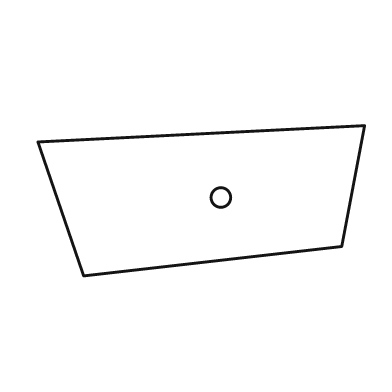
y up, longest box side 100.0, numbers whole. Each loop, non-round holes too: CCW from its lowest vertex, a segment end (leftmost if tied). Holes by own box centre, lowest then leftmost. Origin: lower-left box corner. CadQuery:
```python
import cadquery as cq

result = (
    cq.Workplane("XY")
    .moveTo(14.0, 0.0)
    .lineTo(93.0, 9.0)
    .lineTo(100.0, 46.0)
    .lineTo(0.0, 41.0)
    .close()
    .moveTo(56.0, 24.0)
    .circle(3.0)
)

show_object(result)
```